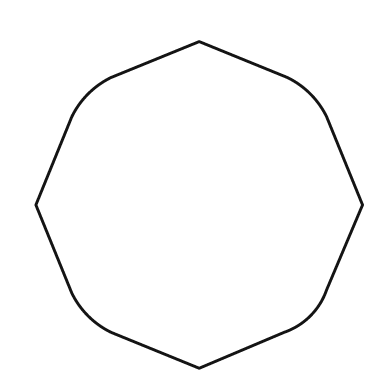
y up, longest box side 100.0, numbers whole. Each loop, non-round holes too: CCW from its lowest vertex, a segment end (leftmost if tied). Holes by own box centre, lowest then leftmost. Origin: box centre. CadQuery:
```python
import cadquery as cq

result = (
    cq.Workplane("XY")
    .moveTo(0.0, -50.0)
    .lineTo(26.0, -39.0)
    .threePointArc((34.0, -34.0), (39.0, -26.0))
    .lineTo(50.0, 0.0)
    .lineTo(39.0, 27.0)
    .threePointArc((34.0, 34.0), (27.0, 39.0))
    .lineTo(0.0, 50.0)
    .lineTo(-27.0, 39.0)
    .threePointArc((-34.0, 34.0), (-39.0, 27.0))
    .lineTo(-50.0, 0.0)
    .lineTo(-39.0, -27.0)
    .threePointArc((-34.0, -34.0), (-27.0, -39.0))
    .close()
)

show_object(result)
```